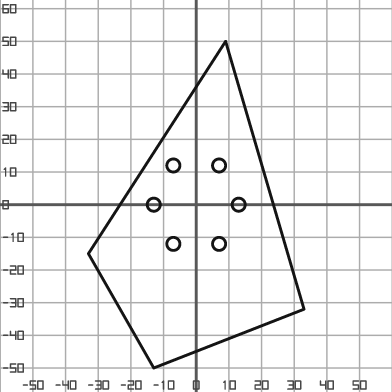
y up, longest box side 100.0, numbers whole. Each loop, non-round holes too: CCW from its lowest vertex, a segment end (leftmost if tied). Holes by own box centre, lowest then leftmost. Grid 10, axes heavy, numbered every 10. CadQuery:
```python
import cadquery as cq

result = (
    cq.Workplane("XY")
    .moveTo(-13.0, -50.0)
    .lineTo(33.0, -32.0)
    .lineTo(9.0, 50.0)
    .lineTo(-33.0, -15.0)
    .close()
    .moveTo(-7.0, -12.0)
    .circle(2.0)
    .moveTo(7.0, -12.0)
    .circle(2.0)
    .moveTo(-13.0, 0.0)
    .circle(2.0)
    .moveTo(13.0, 0.0)
    .circle(2.0)
    .moveTo(-7.0, 12.0)
    .circle(2.0)
    .moveTo(7.0, 12.0)
    .circle(2.0)
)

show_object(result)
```